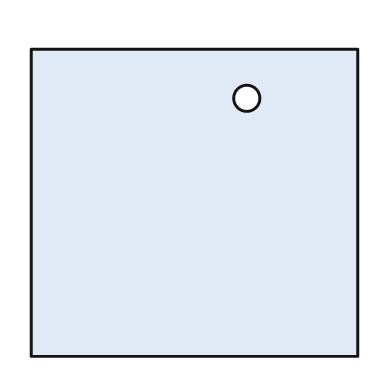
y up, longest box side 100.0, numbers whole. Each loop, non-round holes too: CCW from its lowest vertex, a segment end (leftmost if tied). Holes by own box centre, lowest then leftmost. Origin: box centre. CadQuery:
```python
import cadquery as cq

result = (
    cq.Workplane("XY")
    .moveTo(-50.0, -47.0)
    .lineTo(50.0, -47.0)
    .lineTo(50.0, 47.0)
    .lineTo(-50.0, 47.0)
    .close()
    .moveTo(16.0, 32.0)
    .circle(4.0)
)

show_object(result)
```